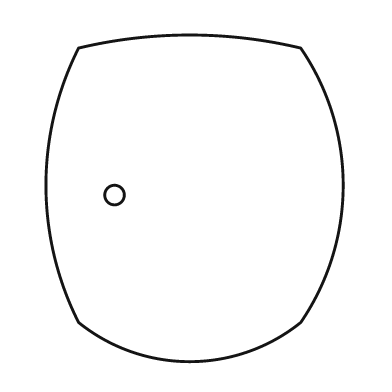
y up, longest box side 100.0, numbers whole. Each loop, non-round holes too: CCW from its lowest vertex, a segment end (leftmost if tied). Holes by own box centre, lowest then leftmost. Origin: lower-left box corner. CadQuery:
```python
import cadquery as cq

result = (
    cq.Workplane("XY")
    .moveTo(10.0, 12.0)
    .threePointArc((44.0, 0.0), (78.0, 12.0))
    .threePointArc((91.0, 54.0), (78.0, 96.0))
    .threePointArc((44.0, 100.0), (10.0, 96.0))
    .threePointArc((0.0, 54.0), (10.0, 12.0))
    .close()
    .moveTo(21.0, 51.0)
    .circle(3.0)
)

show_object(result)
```